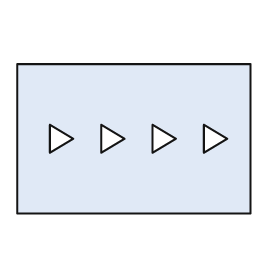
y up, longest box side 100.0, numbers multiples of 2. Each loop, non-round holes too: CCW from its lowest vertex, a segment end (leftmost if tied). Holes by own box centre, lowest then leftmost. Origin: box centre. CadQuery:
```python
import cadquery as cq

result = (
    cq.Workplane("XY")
    .moveTo(-50.0, -32.0)
    .lineTo(50.0, -32.0)
    .lineTo(50.0, 32.0)
    .lineTo(-50.0, 32.0)
    .close()
    .moveTo(-36.0, -6.0)
    .lineTo(-26.0, 0.0)
    .lineTo(-36.0, 6.0)
    .close()
    .moveTo(-14.0, -6.0)
    .lineTo(-4.0, 0.0)
    .lineTo(-14.0, 6.0)
    .close()
    .moveTo(8.0, -6.0)
    .lineTo(18.0, 0.0)
    .lineTo(8.0, 6.0)
    .close()
    .moveTo(30.0, -6.0)
    .lineTo(40.0, 0.0)
    .lineTo(30.0, 6.0)
    .close()
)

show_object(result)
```